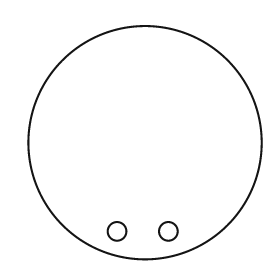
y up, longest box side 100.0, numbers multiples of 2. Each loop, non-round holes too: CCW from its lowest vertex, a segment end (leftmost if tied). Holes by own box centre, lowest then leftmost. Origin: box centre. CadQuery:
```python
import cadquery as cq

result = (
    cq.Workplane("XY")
    .moveTo(0.0, 0.0)
    .circle(50.0)
    .moveTo(-12.0, -38.0)
    .circle(4.0)
    .moveTo(10.0, -38.0)
    .circle(4.0)
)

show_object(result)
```